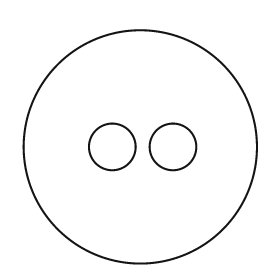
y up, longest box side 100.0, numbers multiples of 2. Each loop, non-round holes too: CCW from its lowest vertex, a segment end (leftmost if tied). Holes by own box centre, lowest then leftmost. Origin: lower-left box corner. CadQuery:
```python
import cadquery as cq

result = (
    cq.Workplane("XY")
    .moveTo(50.0, 50.0)
    .circle(50.0)
    .moveTo(38.0, 50.0)
    .circle(10.0)
    .moveTo(64.0, 50.0)
    .circle(10.0)
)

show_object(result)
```